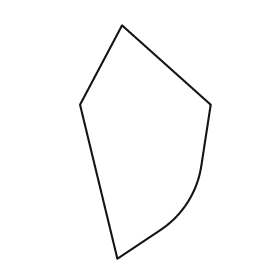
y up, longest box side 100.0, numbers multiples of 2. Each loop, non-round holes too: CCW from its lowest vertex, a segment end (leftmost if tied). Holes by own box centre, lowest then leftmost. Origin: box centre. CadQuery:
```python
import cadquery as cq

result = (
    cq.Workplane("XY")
    .moveTo(-12.0, -50.0)
    .lineTo(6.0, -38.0)
    .threePointArc((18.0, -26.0), (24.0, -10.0))
    .lineTo(28.0, 16.0)
    .lineTo(-10.0, 50.0)
    .lineTo(-28.0, 16.0)
    .close()
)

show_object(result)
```